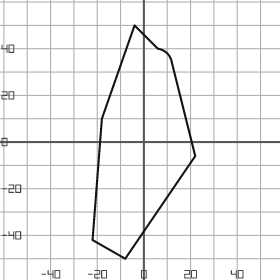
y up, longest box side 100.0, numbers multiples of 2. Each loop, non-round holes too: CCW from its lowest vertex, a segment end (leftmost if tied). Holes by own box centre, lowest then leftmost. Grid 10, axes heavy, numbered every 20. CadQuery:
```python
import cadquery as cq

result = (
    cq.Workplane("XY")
    .moveTo(-8.0, -50.0)
    .lineTo(22.0, -6.0)
    .lineTo(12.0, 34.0)
    .threePointArc((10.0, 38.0), (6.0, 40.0))
    .lineTo(-4.0, 50.0)
    .lineTo(-18.0, 10.0)
    .lineTo(-22.0, -42.0)
    .close()
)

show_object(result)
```